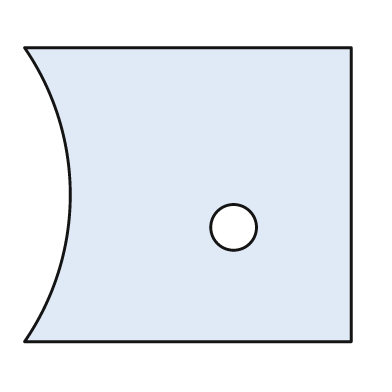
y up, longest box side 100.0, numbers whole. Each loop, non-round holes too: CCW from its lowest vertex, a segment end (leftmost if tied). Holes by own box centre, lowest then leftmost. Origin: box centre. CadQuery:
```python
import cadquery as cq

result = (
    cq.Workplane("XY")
    .moveTo(-50.0, -45.0)
    .lineTo(50.0, -45.0)
    .lineTo(50.0, 45.0)
    .lineTo(-50.0, 45.0)
    .threePointArc((-36.0, 0.0), (-50.0, -45.0))
    .close()
    .moveTo(14.0, -10.0)
    .circle(7.0)
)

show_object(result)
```